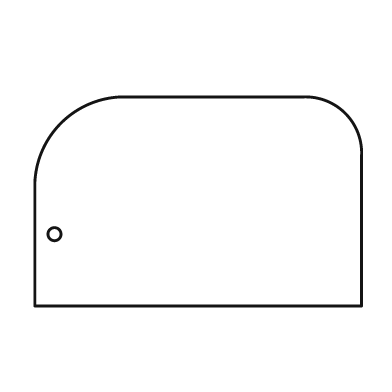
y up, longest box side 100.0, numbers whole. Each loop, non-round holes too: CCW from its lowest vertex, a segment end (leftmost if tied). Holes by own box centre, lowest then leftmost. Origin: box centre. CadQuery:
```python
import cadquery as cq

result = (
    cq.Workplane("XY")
    .moveTo(-50.0, -32.0)
    .lineTo(50.0, -32.0)
    .lineTo(50.0, 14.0)
    .threePointArc((45.0, 27.0), (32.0, 32.0))
    .lineTo(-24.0, 32.0)
    .threePointArc((-42.0, 24.0), (-50.0, 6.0))
    .close()
    .moveTo(-44.0, -10.0)
    .circle(2.0)
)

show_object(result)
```